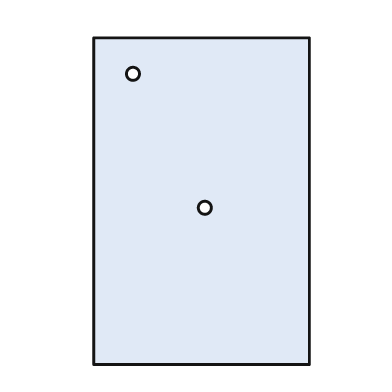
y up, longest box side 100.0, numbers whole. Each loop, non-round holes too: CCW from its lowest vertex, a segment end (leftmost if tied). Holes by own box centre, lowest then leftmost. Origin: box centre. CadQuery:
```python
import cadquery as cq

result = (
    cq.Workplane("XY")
    .moveTo(-33.0, -50.0)
    .lineTo(33.0, -50.0)
    .lineTo(33.0, 50.0)
    .lineTo(-33.0, 50.0)
    .close()
    .moveTo(1.0, -2.0)
    .circle(2.0)
    .moveTo(-21.0, 39.0)
    .circle(2.0)
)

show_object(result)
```